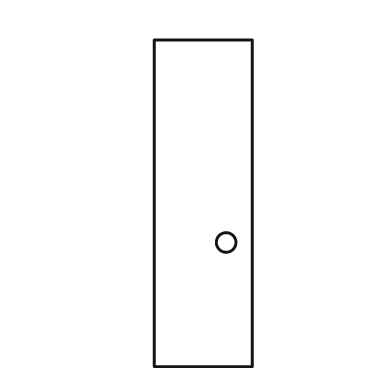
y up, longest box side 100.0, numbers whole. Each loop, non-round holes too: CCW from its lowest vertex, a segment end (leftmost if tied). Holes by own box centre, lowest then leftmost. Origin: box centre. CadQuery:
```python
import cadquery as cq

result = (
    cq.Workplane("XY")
    .moveTo(-15.0, -50.0)
    .lineTo(15.0, -50.0)
    .lineTo(15.0, 50.0)
    .lineTo(-15.0, 50.0)
    .close()
    .moveTo(7.0, -12.0)
    .circle(3.0)
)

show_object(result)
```